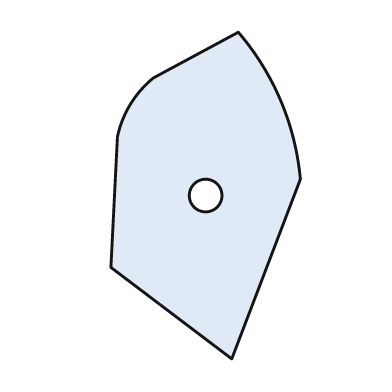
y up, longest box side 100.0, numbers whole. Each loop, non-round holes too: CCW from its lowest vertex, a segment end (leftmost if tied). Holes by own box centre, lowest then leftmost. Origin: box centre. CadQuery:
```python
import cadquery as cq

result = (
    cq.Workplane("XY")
    .moveTo(8.0, -50.0)
    .lineTo(29.0, 5.0)
    .threePointArc((23.0, 29.0), (10.0, 50.0))
    .lineTo(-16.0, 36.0)
    .threePointArc((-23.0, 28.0), (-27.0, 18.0))
    .lineTo(-29.0, -22.0)
    .close()
    .moveTo(0.0, 0.0)
    .circle(5.0)
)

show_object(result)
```